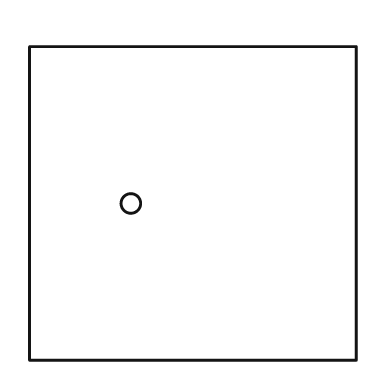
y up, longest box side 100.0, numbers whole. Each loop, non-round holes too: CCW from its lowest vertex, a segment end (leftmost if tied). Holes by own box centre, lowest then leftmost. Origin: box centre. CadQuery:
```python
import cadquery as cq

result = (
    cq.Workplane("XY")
    .moveTo(-50.0, -48.0)
    .lineTo(50.0, -48.0)
    .lineTo(50.0, 48.0)
    .lineTo(-50.0, 48.0)
    .close()
    .moveTo(-19.0, 0.0)
    .circle(3.0)
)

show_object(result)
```